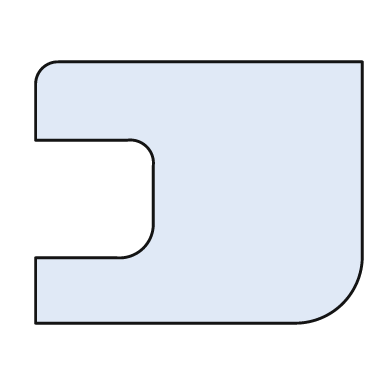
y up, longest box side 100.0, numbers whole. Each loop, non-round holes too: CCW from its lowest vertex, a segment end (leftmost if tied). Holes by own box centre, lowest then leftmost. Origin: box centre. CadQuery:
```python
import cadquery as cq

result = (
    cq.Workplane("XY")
    .moveTo(-50.0, -40.0)
    .lineTo(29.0, -40.0)
    .threePointArc((44.0, -34.0), (50.0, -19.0))
    .lineTo(50.0, 40.0)
    .lineTo(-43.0, 40.0)
    .threePointArc((-48.0, 38.0), (-50.0, 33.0))
    .lineTo(-50.0, 16.0)
    .lineTo(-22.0, 16.0)
    .threePointArc((-16.0, 14.0), (-14.0, 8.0))
    .lineTo(-14.0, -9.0)
    .threePointArc((-17.0, -17.0), (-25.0, -20.0))
    .lineTo(-50.0, -20.0)
    .close()
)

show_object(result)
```